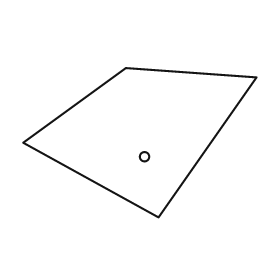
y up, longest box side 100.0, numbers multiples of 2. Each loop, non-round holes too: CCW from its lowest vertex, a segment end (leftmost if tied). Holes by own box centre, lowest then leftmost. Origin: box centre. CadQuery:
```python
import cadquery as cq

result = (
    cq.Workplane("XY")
    .moveTo(8.0, -32.0)
    .lineTo(50.0, 28.0)
    .lineTo(-6.0, 32.0)
    .lineTo(-50.0, 0.0)
    .close()
    .moveTo(2.0, -6.0)
    .circle(2.0)
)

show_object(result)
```